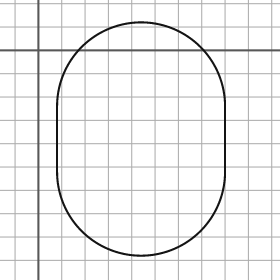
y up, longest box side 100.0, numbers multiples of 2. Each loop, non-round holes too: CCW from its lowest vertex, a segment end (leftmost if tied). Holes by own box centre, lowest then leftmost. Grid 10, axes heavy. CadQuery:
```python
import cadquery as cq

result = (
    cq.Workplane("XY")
    .moveTo(8.0, -52.0)
    .threePointArc((44.0, -88.0), (80.0, -52.0))
    .lineTo(80.0, -24.0)
    .threePointArc((44.0, 12.0), (8.0, -24.0))
    .close()
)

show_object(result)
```